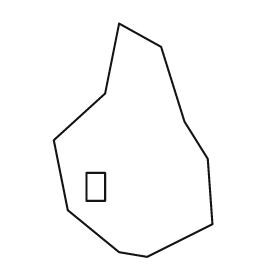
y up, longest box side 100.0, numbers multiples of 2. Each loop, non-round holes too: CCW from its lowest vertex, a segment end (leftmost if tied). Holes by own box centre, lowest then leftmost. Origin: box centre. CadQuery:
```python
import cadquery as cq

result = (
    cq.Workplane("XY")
    .moveTo(6.0, -50.0)
    .lineTo(34.0, -36.0)
    .lineTo(32.0, -8.0)
    .lineTo(22.0, 8.0)
    .lineTo(12.0, 40.0)
    .lineTo(-6.0, 50.0)
    .lineTo(-12.0, 20.0)
    .lineTo(-34.0, 0.0)
    .lineTo(-28.0, -30.0)
    .lineTo(-6.0, -48.0)
    .close()
    .moveTo(-20.0, -26.0)
    .lineTo(-12.0, -26.0)
    .lineTo(-12.0, -14.0)
    .lineTo(-20.0, -14.0)
    .close()
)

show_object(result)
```